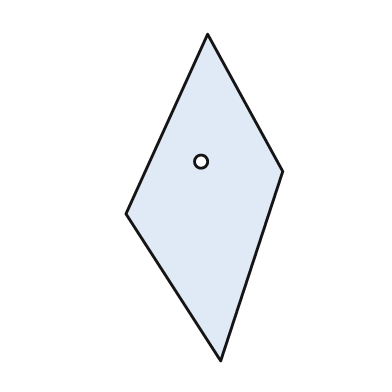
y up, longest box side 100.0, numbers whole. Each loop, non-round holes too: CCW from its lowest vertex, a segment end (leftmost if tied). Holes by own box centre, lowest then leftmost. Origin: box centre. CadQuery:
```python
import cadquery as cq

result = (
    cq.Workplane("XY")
    .moveTo(5.0, -50.0)
    .lineTo(24.0, 8.0)
    .lineTo(1.0, 50.0)
    .lineTo(-24.0, -5.0)
    .close()
    .moveTo(-1.0, 11.0)
    .circle(2.0)
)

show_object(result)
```